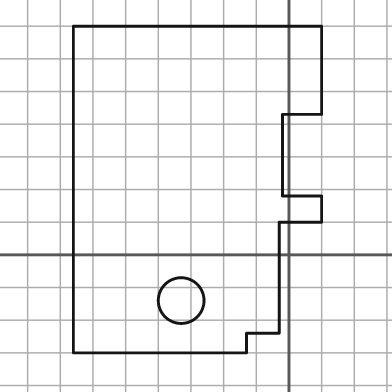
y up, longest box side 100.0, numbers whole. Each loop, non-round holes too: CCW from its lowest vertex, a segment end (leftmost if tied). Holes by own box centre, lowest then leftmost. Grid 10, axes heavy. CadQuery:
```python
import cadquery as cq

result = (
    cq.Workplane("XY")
    .moveTo(-66.0, -30.0)
    .lineTo(-13.0, -30.0)
    .lineTo(-13.0, -24.0)
    .lineTo(-3.0, -24.0)
    .lineTo(-3.0, 10.0)
    .lineTo(10.0, 10.0)
    .lineTo(10.0, 18.0)
    .lineTo(-2.0, 18.0)
    .lineTo(-2.0, 43.0)
    .lineTo(10.0, 43.0)
    .lineTo(10.0, 70.0)
    .lineTo(-66.0, 70.0)
    .close()
    .moveTo(-33.0, -14.0)
    .circle(7.0)
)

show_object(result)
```